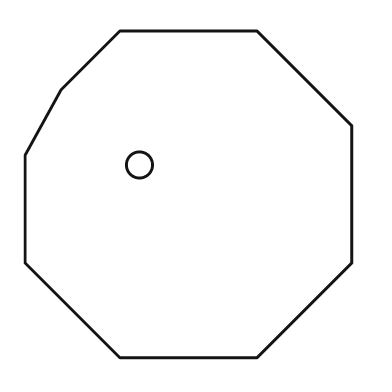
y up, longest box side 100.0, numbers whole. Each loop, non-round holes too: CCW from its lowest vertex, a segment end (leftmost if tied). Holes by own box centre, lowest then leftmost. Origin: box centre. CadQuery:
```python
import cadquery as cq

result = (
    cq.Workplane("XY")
    .moveTo(-21.0, -50.0)
    .lineTo(21.0, -50.0)
    .lineTo(50.0, -21.0)
    .lineTo(50.0, 21.0)
    .lineTo(21.0, 50.0)
    .lineTo(-21.0, 50.0)
    .lineTo(-39.0, 32.0)
    .lineTo(-50.0, 12.0)
    .lineTo(-50.0, -21.0)
    .close()
    .moveTo(-15.0, 9.0)
    .circle(4.0)
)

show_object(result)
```